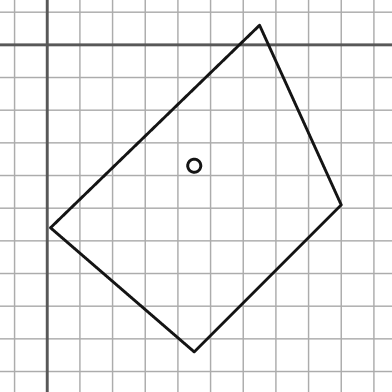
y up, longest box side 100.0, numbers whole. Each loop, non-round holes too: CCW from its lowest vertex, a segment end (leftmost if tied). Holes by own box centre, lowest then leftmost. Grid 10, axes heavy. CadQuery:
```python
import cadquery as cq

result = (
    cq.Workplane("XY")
    .moveTo(45.0, -94.0)
    .lineTo(90.0, -49.0)
    .lineTo(65.0, 6.0)
    .lineTo(1.0, -56.0)
    .close()
    .moveTo(45.0, -37.0)
    .circle(2.0)
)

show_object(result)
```